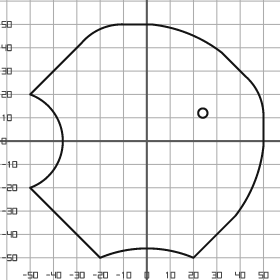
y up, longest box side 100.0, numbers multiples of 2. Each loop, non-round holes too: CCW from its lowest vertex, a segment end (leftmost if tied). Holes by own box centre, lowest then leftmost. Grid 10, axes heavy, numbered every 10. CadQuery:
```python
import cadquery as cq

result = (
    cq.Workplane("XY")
    .moveTo(-20.0, -50.0)
    .threePointArc((0.0, -46.0), (20.0, -50.0))
    .lineTo(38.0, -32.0)
    .threePointArc((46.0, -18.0), (50.0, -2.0))
    .lineTo(50.0, 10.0)
    .threePointArc((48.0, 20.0), (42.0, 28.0))
    .lineTo(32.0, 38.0)
    .threePointArc((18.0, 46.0), (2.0, 50.0))
    .lineTo(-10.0, 50.0)
    .threePointArc((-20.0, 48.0), (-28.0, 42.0))
    .lineTo(-50.0, 20.0)
    .threePointArc((-36.0, 0.0), (-50.0, -20.0))
    .close()
    .moveTo(24.0, 12.0)
    .circle(2.0)
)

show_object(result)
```